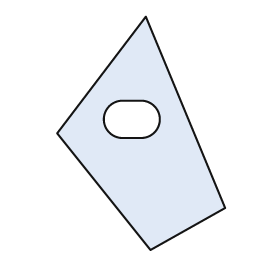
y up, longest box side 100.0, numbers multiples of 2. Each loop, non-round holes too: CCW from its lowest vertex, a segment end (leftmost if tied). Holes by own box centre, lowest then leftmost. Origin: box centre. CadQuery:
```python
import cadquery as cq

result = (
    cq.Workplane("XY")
    .moveTo(4.0, -50.0)
    .lineTo(36.0, -32.0)
    .lineTo(2.0, 50.0)
    .lineTo(-36.0, 0.0)
    .close()
    .moveTo(-8.0, -2.0)
    .lineTo(0.0, -2.0)
    .threePointArc((8.0, 6.0), (0.0, 14.0))
    .lineTo(-8.0, 14.0)
    .threePointArc((-16.0, 6.0), (-8.0, -2.0))
    .close()
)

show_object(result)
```